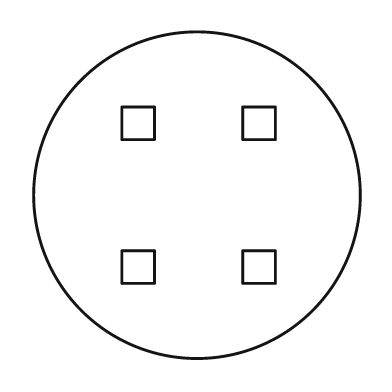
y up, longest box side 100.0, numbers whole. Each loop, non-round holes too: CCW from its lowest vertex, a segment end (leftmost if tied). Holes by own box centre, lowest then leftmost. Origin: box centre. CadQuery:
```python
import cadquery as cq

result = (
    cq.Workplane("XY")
    .moveTo(0.0, 0.0)
    .circle(50.0)
    .moveTo(-23.0, -27.0)
    .lineTo(-13.0, -27.0)
    .lineTo(-13.0, -17.0)
    .lineTo(-23.0, -17.0)
    .close()
    .moveTo(14.0, -27.0)
    .lineTo(24.0, -27.0)
    .lineTo(24.0, -17.0)
    .lineTo(14.0, -17.0)
    .close()
    .moveTo(-23.0, 17.0)
    .lineTo(-13.0, 17.0)
    .lineTo(-13.0, 27.0)
    .lineTo(-23.0, 27.0)
    .close()
    .moveTo(14.0, 17.0)
    .lineTo(24.0, 17.0)
    .lineTo(24.0, 27.0)
    .lineTo(14.0, 27.0)
    .close()
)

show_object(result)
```